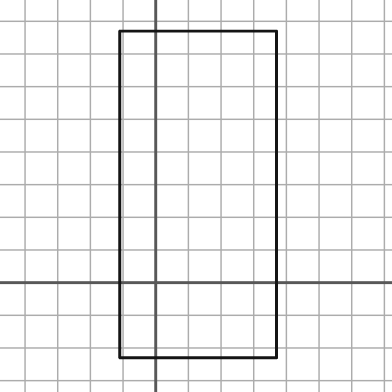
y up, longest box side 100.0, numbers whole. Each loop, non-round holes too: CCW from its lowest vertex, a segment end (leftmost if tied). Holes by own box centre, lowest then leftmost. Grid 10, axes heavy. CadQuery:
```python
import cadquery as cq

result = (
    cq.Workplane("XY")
    .moveTo(-11.0, -23.0)
    .lineTo(37.0, -23.0)
    .lineTo(37.0, 77.0)
    .lineTo(-11.0, 77.0)
    .close()
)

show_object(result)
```